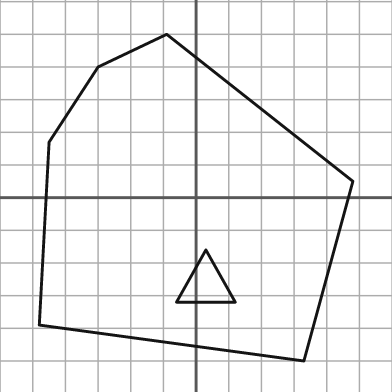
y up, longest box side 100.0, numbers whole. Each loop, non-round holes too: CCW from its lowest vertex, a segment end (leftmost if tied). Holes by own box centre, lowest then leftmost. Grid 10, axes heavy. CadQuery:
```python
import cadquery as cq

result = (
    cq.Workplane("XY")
    .moveTo(33.0, -50.0)
    .lineTo(48.0, 5.0)
    .lineTo(-9.0, 50.0)
    .lineTo(-30.0, 40.0)
    .lineTo(-45.0, 17.0)
    .lineTo(-48.0, -39.0)
    .close()
    .moveTo(-6.0, -32.0)
    .lineTo(12.0, -32.0)
    .lineTo(3.0, -16.0)
    .close()
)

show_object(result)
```